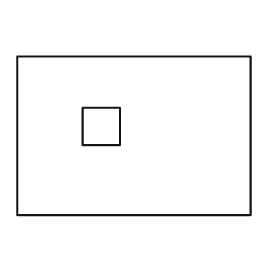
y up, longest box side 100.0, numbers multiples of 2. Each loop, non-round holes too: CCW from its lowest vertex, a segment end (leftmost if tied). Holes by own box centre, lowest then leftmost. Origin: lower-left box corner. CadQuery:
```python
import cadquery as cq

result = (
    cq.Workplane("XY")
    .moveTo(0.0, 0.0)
    .lineTo(100.0, 0.0)
    .lineTo(100.0, 68.0)
    .lineTo(0.0, 68.0)
    .close()
    .moveTo(28.0, 30.0)
    .lineTo(44.0, 30.0)
    .lineTo(44.0, 46.0)
    .lineTo(28.0, 46.0)
    .close()
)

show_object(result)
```